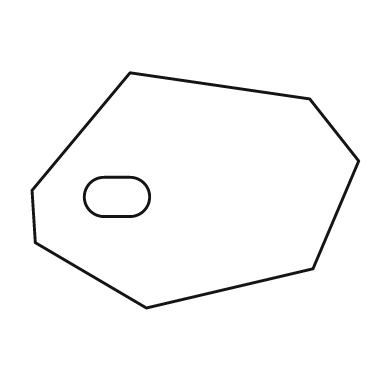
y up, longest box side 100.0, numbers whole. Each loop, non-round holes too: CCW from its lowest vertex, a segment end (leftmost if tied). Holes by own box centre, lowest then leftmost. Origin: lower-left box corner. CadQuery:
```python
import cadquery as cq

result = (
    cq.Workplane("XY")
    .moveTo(35.0, 0.0)
    .lineTo(86.0, 12.0)
    .lineTo(100.0, 45.0)
    .lineTo(85.0, 64.0)
    .lineTo(30.0, 72.0)
    .lineTo(0.0, 36.0)
    .lineTo(1.0, 20.0)
    .close()
    .moveTo(22.0, 28.0)
    .lineTo(30.0, 28.0)
    .threePointArc((36.0, 34.0), (30.0, 40.0))
    .lineTo(22.0, 40.0)
    .threePointArc((16.0, 34.0), (22.0, 28.0))
    .close()
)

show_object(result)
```